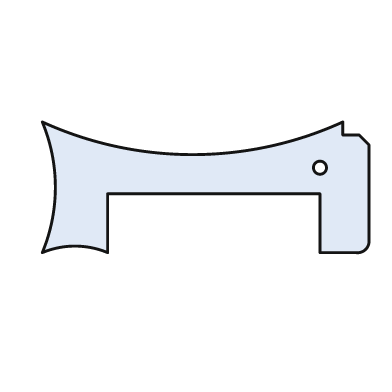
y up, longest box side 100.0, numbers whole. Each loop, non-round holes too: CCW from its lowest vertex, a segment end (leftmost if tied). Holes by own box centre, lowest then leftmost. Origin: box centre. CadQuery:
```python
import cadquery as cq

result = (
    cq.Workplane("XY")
    .moveTo(-50.0, -20.0)
    .threePointArc((-40.0, -18.0), (-30.0, -20.0))
    .lineTo(-30.0, -2.0)
    .lineTo(35.0, -2.0)
    .lineTo(35.0, -20.0)
    .lineTo(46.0, -20.0)
    .threePointArc((49.0, -19.0), (50.0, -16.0))
    .lineTo(50.0, 13.0)
    .lineTo(47.0, 16.0)
    .lineTo(42.0, 16.0)
    .lineTo(42.0, 20.0)
    .threePointArc((-4.0, 10.0), (-50.0, 20.0))
    .threePointArc((-46.0, 0.0), (-50.0, -20.0))
    .close()
    .moveTo(35.0, 6.0)
    .circle(2.0)
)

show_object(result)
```